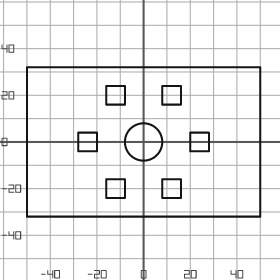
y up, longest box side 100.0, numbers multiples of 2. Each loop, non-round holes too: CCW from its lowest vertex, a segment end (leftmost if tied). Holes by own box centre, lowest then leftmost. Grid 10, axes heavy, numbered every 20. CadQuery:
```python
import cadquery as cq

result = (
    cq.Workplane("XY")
    .moveTo(-50.0, -32.0)
    .lineTo(50.0, -32.0)
    .lineTo(50.0, 32.0)
    .lineTo(-50.0, 32.0)
    .close()
    .moveTo(-16.0, -24.0)
    .lineTo(-8.0, -24.0)
    .lineTo(-8.0, -16.0)
    .lineTo(-16.0, -16.0)
    .close()
    .moveTo(8.0, -24.0)
    .lineTo(16.0, -24.0)
    .lineTo(16.0, -16.0)
    .lineTo(8.0, -16.0)
    .close()
    .moveTo(-28.0, -4.0)
    .lineTo(-20.0, -4.0)
    .lineTo(-20.0, 4.0)
    .lineTo(-28.0, 4.0)
    .close()
    .moveTo(0.0, 0.0)
    .circle(8.0)
    .moveTo(20.0, -4.0)
    .lineTo(28.0, -4.0)
    .lineTo(28.0, 4.0)
    .lineTo(20.0, 4.0)
    .close()
    .moveTo(-16.0, 16.0)
    .lineTo(-8.0, 16.0)
    .lineTo(-8.0, 24.0)
    .lineTo(-16.0, 24.0)
    .close()
    .moveTo(8.0, 16.0)
    .lineTo(16.0, 16.0)
    .lineTo(16.0, 24.0)
    .lineTo(8.0, 24.0)
    .close()
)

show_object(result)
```